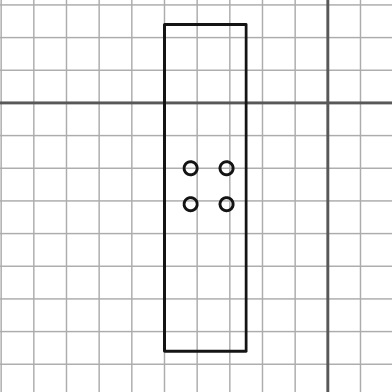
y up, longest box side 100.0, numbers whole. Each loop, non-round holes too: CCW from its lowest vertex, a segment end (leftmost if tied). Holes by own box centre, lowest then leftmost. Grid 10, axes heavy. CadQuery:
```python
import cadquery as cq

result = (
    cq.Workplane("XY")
    .moveTo(-50.0, -76.0)
    .lineTo(-25.0, -76.0)
    .lineTo(-25.0, 24.0)
    .lineTo(-50.0, 24.0)
    .close()
    .moveTo(-42.0, -31.0)
    .circle(2.0)
    .moveTo(-31.0, -31.0)
    .circle(2.0)
    .moveTo(-42.0, -20.0)
    .circle(2.0)
    .moveTo(-31.0, -20.0)
    .circle(2.0)
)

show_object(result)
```